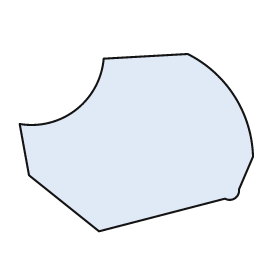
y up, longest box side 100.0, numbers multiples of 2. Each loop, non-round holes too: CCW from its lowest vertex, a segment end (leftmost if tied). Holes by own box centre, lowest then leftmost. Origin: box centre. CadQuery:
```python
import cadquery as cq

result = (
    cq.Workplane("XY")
    .moveTo(-16.0, -38.0)
    .lineTo(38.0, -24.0)
    .threePointArc((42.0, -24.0), (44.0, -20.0))
    .lineTo(50.0, -6.0)
    .threePointArc((42.0, 20.0), (22.0, 38.0))
    .lineTo(-14.0, 36.0)
    .threePointArc((-26.0, 14.0), (-50.0, 8.0))
    .lineTo(-46.0, -14.0)
    .close()
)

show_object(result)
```